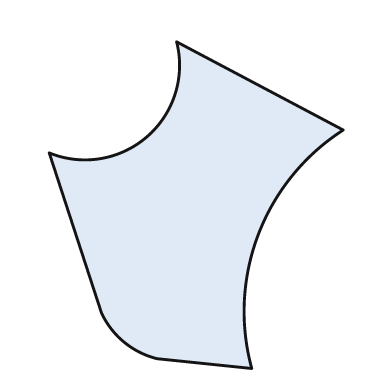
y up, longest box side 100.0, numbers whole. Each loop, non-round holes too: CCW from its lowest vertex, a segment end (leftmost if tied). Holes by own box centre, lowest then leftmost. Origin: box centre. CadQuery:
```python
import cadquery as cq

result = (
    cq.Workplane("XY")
    .moveTo(17.0, -50.0)
    .threePointArc((19.0, -9.0), (45.0, 23.0))
    .lineTo(-6.0, 50.0)
    .threePointArc((-15.0, 21.0), (-45.0, 16.0))
    .lineTo(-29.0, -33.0)
    .threePointArc((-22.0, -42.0), (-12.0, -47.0))
    .close()
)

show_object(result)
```